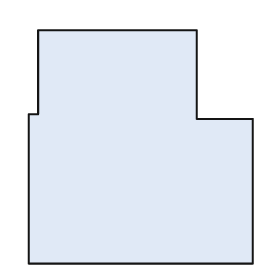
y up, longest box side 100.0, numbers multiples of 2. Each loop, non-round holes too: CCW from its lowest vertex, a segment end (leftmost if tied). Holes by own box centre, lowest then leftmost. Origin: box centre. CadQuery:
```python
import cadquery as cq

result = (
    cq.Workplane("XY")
    .moveTo(-48.0, -50.0)
    .lineTo(48.0, -50.0)
    .lineTo(48.0, 12.0)
    .lineTo(24.0, 12.0)
    .lineTo(24.0, 50.0)
    .lineTo(-44.0, 50.0)
    .lineTo(-44.0, 14.0)
    .lineTo(-48.0, 14.0)
    .close()
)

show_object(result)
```